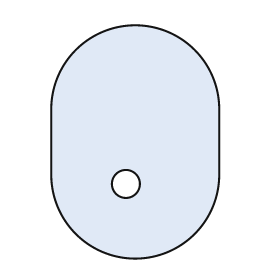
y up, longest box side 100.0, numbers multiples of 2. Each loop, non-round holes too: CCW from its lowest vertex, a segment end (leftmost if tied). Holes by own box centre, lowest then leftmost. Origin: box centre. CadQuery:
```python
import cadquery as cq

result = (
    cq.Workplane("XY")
    .moveTo(-36.0, -14.0)
    .threePointArc((0.0, -50.0), (36.0, -14.0))
    .lineTo(36.0, 14.0)
    .threePointArc((0.0, 50.0), (-36.0, 14.0))
    .close()
    .moveTo(-4.0, -18.0)
    .circle(6.0)
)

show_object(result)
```